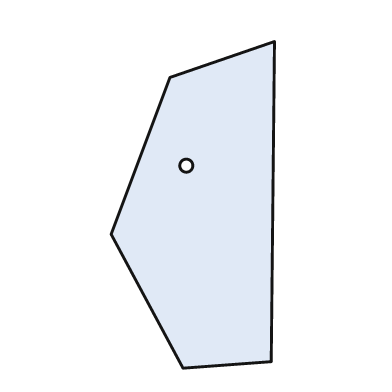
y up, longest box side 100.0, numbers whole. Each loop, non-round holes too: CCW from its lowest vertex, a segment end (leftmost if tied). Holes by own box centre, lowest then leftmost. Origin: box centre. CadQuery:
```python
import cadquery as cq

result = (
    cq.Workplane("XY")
    .moveTo(-3.0, -50.0)
    .lineTo(24.0, -48.0)
    .lineTo(25.0, 50.0)
    .lineTo(-7.0, 39.0)
    .lineTo(-25.0, -9.0)
    .close()
    .moveTo(-2.0, 12.0)
    .circle(2.0)
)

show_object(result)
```